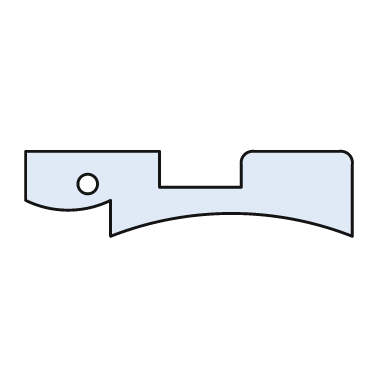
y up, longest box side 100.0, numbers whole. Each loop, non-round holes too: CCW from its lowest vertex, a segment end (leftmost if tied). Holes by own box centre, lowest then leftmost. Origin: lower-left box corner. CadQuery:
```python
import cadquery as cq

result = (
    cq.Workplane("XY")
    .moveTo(26.0, 0.0)
    .threePointArc((63.0, 7.0), (100.0, 0.0))
    .lineTo(100.0, 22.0)
    .threePointArc((99.0, 25.0), (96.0, 26.0))
    .lineTo(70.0, 26.0)
    .threePointArc((67.0, 25.0), (66.0, 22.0))
    .lineTo(66.0, 15.0)
    .lineTo(41.0, 15.0)
    .lineTo(41.0, 26.0)
    .lineTo(0.0, 26.0)
    .lineTo(0.0, 11.0)
    .threePointArc((13.0, 8.0), (26.0, 11.0))
    .close()
    .moveTo(19.0, 16.0)
    .circle(3.0)
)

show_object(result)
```